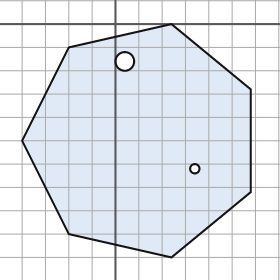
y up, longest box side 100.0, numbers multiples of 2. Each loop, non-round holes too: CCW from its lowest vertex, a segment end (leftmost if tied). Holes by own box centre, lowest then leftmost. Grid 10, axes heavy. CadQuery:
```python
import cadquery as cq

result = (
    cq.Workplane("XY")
    .moveTo(24.0, -100.0)
    .lineTo(58.0, -72.0)
    .lineTo(58.0, -28.0)
    .lineTo(24.0, 0.0)
    .lineTo(-20.0, -10.0)
    .lineTo(-40.0, -50.0)
    .lineTo(-20.0, -90.0)
    .close()
    .moveTo(34.0, -62.0)
    .circle(2.0)
    .moveTo(4.0, -16.0)
    .circle(4.0)
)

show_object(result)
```